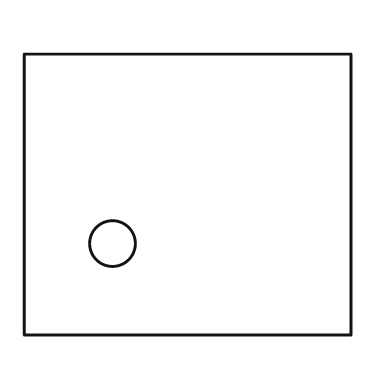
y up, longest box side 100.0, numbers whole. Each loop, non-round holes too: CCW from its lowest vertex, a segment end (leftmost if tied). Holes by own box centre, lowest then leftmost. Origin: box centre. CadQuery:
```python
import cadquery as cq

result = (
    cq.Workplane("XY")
    .moveTo(-50.0, -43.0)
    .lineTo(50.0, -43.0)
    .lineTo(50.0, 43.0)
    .lineTo(-50.0, 43.0)
    .close()
    .moveTo(-23.0, -15.0)
    .circle(7.0)
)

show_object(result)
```